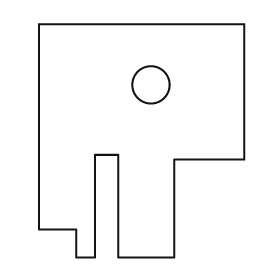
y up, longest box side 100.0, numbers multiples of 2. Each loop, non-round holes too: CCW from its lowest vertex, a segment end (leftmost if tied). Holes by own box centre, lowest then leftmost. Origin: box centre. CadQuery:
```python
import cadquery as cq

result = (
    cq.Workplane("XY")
    .moveTo(-28.0, -50.0)
    .lineTo(-20.0, -50.0)
    .lineTo(-20.0, -6.0)
    .lineTo(-10.0, -6.0)
    .lineTo(-10.0, -50.0)
    .lineTo(14.0, -50.0)
    .lineTo(14.0, -8.0)
    .lineTo(44.0, -8.0)
    .lineTo(44.0, 50.0)
    .lineTo(-44.0, 50.0)
    .lineTo(-44.0, -38.0)
    .lineTo(-28.0, -38.0)
    .close()
    .moveTo(4.0, 24.0)
    .circle(8.0)
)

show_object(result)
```